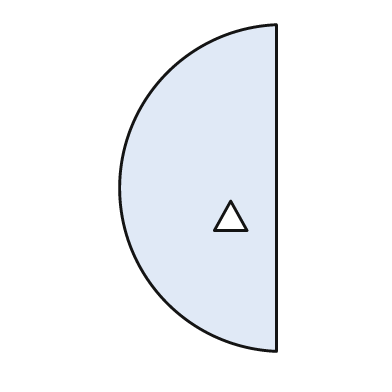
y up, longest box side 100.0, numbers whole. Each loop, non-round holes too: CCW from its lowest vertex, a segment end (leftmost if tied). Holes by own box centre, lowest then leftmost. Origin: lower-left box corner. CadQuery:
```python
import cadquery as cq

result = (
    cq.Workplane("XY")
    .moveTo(48.0, 0.0)
    .lineTo(48.0, 100.0)
    .threePointArc((0.0, 50.0), (48.0, 0.0))
    .close()
    .moveTo(29.0, 37.0)
    .lineTo(39.0, 37.0)
    .lineTo(34.0, 46.0)
    .close()
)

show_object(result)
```